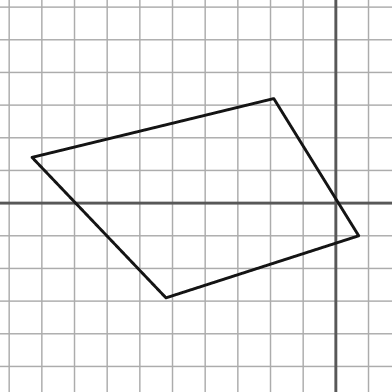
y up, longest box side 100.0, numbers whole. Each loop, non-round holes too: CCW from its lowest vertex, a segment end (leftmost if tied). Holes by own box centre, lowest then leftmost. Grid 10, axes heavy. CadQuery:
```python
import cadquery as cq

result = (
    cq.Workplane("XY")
    .moveTo(-52.0, -29.0)
    .lineTo(7.0, -10.0)
    .lineTo(-19.0, 32.0)
    .lineTo(-93.0, 14.0)
    .close()
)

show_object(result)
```